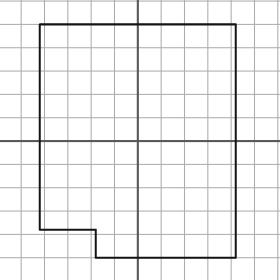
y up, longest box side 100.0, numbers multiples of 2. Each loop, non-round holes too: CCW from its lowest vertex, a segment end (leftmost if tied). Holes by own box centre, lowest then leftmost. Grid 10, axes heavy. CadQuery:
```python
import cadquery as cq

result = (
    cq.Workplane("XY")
    .moveTo(-18.0, -50.0)
    .lineTo(42.0, -50.0)
    .lineTo(42.0, 50.0)
    .lineTo(-42.0, 50.0)
    .lineTo(-42.0, -38.0)
    .lineTo(-18.0, -38.0)
    .close()
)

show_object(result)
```